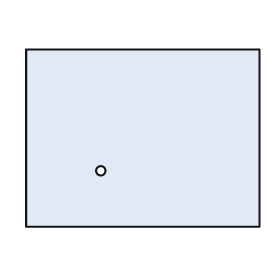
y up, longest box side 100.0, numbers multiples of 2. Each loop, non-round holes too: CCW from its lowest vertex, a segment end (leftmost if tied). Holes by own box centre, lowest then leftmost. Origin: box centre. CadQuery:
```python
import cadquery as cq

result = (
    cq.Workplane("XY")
    .moveTo(-50.0, -38.0)
    .lineTo(50.0, -38.0)
    .lineTo(50.0, 38.0)
    .lineTo(-50.0, 38.0)
    .close()
    .moveTo(-18.0, -14.0)
    .circle(2.0)
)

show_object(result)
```